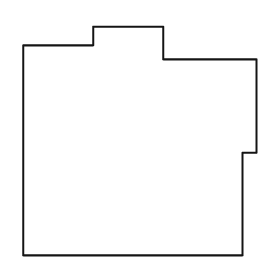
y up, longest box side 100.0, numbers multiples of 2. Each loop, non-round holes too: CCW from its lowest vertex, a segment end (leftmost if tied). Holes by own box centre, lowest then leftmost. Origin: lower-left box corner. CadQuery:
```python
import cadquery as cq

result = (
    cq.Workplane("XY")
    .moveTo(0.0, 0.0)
    .lineTo(94.0, 0.0)
    .lineTo(94.0, 44.0)
    .lineTo(100.0, 44.0)
    .lineTo(100.0, 84.0)
    .lineTo(60.0, 84.0)
    .lineTo(60.0, 98.0)
    .lineTo(30.0, 98.0)
    .lineTo(30.0, 90.0)
    .lineTo(0.0, 90.0)
    .close()
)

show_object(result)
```